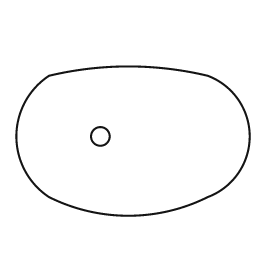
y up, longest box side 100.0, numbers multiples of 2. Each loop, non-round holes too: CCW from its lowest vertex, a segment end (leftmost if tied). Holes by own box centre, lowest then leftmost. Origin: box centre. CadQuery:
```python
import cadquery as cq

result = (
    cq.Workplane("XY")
    .moveTo(-36.0, -24.0)
    .threePointArc((-2.0, -32.0), (32.0, -24.0))
    .threePointArc((50.0, 2.0), (32.0, 28.0))
    .threePointArc((-2.0, 32.0), (-36.0, 28.0))
    .threePointArc((-50.0, 2.0), (-36.0, -24.0))
    .close()
    .moveTo(-14.0, 2.0)
    .circle(4.0)
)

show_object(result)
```